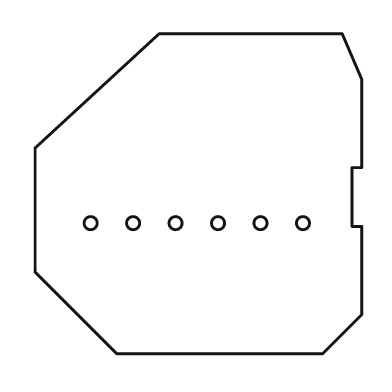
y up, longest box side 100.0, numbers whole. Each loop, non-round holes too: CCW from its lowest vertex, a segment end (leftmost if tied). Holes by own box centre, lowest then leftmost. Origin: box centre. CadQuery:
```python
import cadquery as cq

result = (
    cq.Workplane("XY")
    .moveTo(-25.0, -49.0)
    .lineTo(38.0, -49.0)
    .lineTo(50.0, -37.0)
    .lineTo(50.0, -10.0)
    .lineTo(47.0, -10.0)
    .lineTo(47.0, 8.0)
    .lineTo(50.0, 8.0)
    .lineTo(50.0, 35.0)
    .lineTo(44.0, 49.0)
    .lineTo(-12.0, 49.0)
    .lineTo(-50.0, 14.0)
    .lineTo(-50.0, -24.0)
    .close()
    .moveTo(-33.0, -9.0)
    .circle(2.0)
    .moveTo(-20.0, -9.0)
    .circle(2.0)
    .moveTo(-7.0, -9.0)
    .circle(2.0)
    .moveTo(6.0, -9.0)
    .circle(2.0)
    .moveTo(19.0, -9.0)
    .circle(2.0)
    .moveTo(32.0, -9.0)
    .circle(2.0)
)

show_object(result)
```